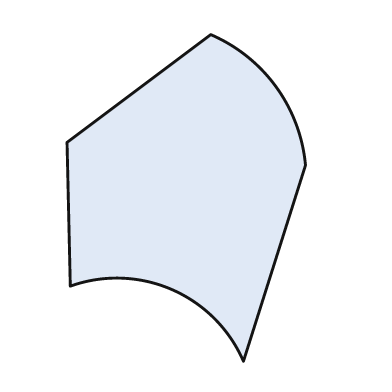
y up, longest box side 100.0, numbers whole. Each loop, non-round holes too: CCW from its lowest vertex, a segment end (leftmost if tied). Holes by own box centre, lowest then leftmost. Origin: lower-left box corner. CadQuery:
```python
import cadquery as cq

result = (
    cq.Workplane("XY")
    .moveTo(54.0, 0.0)
    .lineTo(73.0, 60.0)
    .threePointArc((64.0, 84.0), (44.0, 100.0))
    .lineTo(0.0, 67.0)
    .lineTo(1.0, 23.0)
    .threePointArc((32.0, 22.0), (54.0, 0.0))
    .close()
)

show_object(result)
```